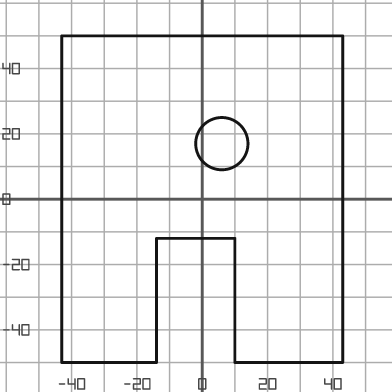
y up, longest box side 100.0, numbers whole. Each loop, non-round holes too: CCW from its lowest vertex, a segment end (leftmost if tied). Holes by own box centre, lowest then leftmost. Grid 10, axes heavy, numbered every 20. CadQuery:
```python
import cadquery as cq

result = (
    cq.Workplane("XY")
    .moveTo(-43.0, -50.0)
    .lineTo(-14.0, -50.0)
    .lineTo(-14.0, -12.0)
    .lineTo(10.0, -12.0)
    .lineTo(10.0, -50.0)
    .lineTo(43.0, -50.0)
    .lineTo(43.0, 50.0)
    .lineTo(-43.0, 50.0)
    .close()
    .moveTo(6.0, 17.0)
    .circle(8.0)
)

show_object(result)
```